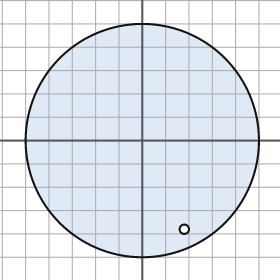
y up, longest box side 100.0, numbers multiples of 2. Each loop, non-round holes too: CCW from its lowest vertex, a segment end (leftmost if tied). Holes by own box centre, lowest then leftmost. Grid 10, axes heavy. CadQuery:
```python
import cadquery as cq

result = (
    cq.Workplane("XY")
    .moveTo(0.0, 0.0)
    .circle(50.0)
    .moveTo(18.0, -38.0)
    .circle(2.0)
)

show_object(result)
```